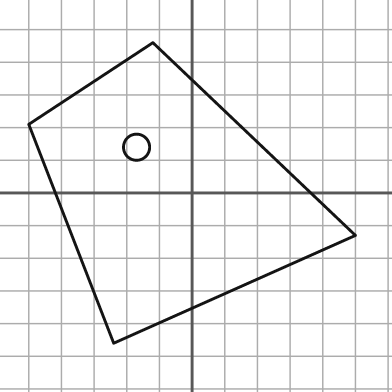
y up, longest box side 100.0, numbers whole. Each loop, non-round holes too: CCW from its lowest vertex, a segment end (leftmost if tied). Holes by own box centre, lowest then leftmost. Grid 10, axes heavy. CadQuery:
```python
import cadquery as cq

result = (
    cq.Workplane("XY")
    .moveTo(-24.0, -46.0)
    .lineTo(50.0, -13.0)
    .lineTo(-12.0, 46.0)
    .lineTo(-50.0, 21.0)
    .close()
    .moveTo(-17.0, 14.0)
    .circle(4.0)
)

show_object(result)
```